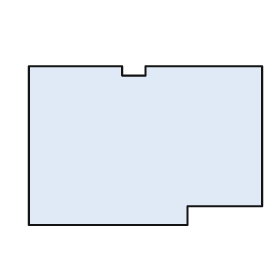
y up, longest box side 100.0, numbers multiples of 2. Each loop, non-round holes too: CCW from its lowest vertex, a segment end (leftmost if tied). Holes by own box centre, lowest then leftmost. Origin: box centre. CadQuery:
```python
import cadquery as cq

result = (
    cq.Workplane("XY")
    .moveTo(-50.0, -34.0)
    .lineTo(18.0, -34.0)
    .lineTo(18.0, -26.0)
    .lineTo(50.0, -26.0)
    .lineTo(50.0, 34.0)
    .lineTo(0.0, 34.0)
    .lineTo(0.0, 30.0)
    .lineTo(-10.0, 30.0)
    .lineTo(-10.0, 34.0)
    .lineTo(-50.0, 34.0)
    .close()
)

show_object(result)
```